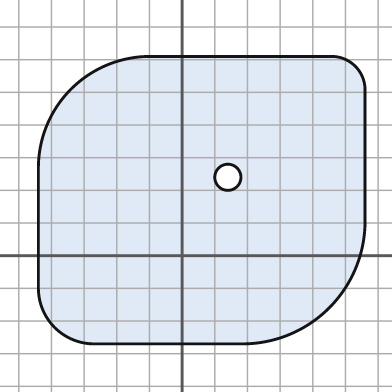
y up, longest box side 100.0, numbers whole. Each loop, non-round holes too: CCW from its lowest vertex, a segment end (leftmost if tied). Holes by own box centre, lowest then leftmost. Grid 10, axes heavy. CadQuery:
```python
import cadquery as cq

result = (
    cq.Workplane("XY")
    .moveTo(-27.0, -27.0)
    .lineTo(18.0, -27.0)
    .threePointArc((45.0, -16.0), (56.0, 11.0))
    .lineTo(56.0, 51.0)
    .threePointArc((53.0, 58.0), (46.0, 61.0))
    .lineTo(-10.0, 61.0)
    .threePointArc((-34.0, 51.0), (-44.0, 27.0))
    .lineTo(-44.0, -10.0)
    .threePointArc((-39.0, -22.0), (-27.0, -27.0))
    .close()
    .moveTo(14.0, 24.0)
    .circle(4.0)
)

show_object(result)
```